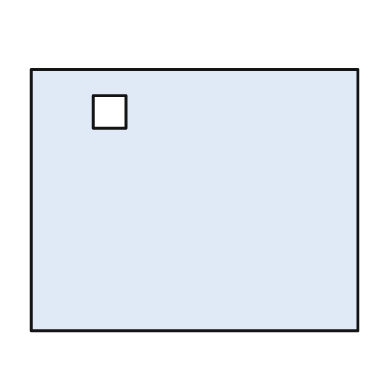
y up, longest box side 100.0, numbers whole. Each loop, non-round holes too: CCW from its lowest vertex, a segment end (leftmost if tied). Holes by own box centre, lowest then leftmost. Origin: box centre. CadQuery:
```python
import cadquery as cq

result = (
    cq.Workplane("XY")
    .moveTo(-50.0, -40.0)
    .lineTo(50.0, -40.0)
    .lineTo(50.0, 40.0)
    .lineTo(-50.0, 40.0)
    .close()
    .moveTo(-31.0, 22.0)
    .lineTo(-21.0, 22.0)
    .lineTo(-21.0, 32.0)
    .lineTo(-31.0, 32.0)
    .close()
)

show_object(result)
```